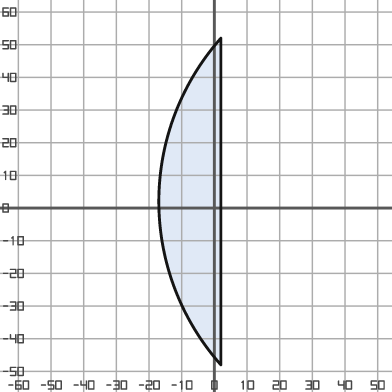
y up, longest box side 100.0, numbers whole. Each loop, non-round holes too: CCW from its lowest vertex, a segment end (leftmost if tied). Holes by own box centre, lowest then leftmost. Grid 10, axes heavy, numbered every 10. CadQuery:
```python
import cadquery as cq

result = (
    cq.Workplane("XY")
    .moveTo(2.0, -48.0)
    .lineTo(2.0, 52.0)
    .threePointArc((-17.0, 2.0), (2.0, -48.0))
    .close()
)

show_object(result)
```